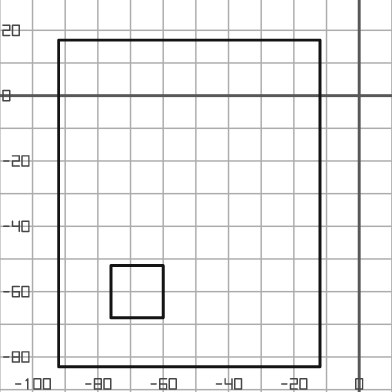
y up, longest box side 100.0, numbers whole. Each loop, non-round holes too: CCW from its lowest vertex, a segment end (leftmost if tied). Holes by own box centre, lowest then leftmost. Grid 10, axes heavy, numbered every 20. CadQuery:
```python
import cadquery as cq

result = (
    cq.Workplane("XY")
    .moveTo(-92.0, -83.0)
    .lineTo(-12.0, -83.0)
    .lineTo(-12.0, 17.0)
    .lineTo(-92.0, 17.0)
    .close()
    .moveTo(-76.0, -68.0)
    .lineTo(-60.0, -68.0)
    .lineTo(-60.0, -52.0)
    .lineTo(-76.0, -52.0)
    .close()
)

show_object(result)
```